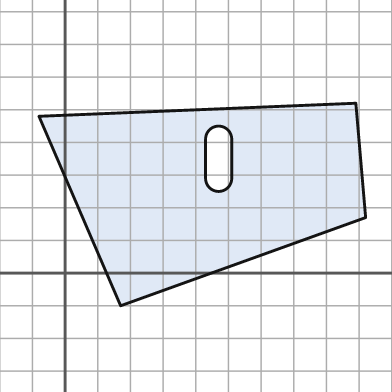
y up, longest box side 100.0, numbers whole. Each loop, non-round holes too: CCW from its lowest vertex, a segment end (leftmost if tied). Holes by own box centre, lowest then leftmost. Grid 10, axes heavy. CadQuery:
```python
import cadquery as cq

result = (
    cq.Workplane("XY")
    .moveTo(17.0, -10.0)
    .lineTo(92.0, 17.0)
    .lineTo(89.0, 52.0)
    .lineTo(-8.0, 48.0)
    .close()
    .moveTo(43.0, 29.0)
    .threePointArc((47.0, 25.0), (51.0, 29.0))
    .lineTo(51.0, 41.0)
    .threePointArc((47.0, 45.0), (43.0, 41.0))
    .close()
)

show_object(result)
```